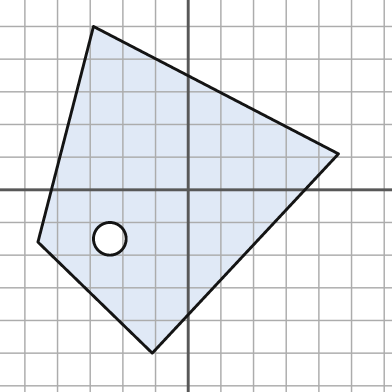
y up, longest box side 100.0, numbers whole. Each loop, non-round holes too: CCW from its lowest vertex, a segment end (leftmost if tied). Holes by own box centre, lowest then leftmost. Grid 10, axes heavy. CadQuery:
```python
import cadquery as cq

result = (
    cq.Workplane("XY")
    .moveTo(-11.0, -50.0)
    .lineTo(46.0, 11.0)
    .lineTo(-29.0, 50.0)
    .lineTo(-46.0, -16.0)
    .close()
    .moveTo(-24.0, -15.0)
    .circle(5.0)
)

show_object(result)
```